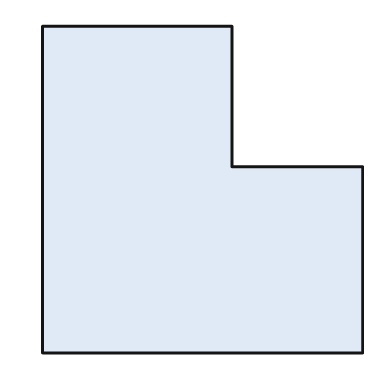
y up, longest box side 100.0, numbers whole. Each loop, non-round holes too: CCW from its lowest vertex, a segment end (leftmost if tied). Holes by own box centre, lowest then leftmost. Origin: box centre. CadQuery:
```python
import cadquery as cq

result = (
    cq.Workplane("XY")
    .moveTo(-49.0, -50.0)
    .lineTo(49.0, -50.0)
    .lineTo(49.0, 7.0)
    .lineTo(9.0, 7.0)
    .lineTo(9.0, 50.0)
    .lineTo(-49.0, 50.0)
    .close()
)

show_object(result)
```